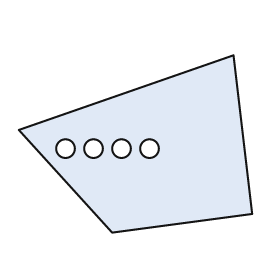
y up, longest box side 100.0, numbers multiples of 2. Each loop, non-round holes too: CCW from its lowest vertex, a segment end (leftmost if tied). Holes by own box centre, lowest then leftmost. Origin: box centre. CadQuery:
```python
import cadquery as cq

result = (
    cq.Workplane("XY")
    .moveTo(-10.0, -38.0)
    .lineTo(50.0, -30.0)
    .lineTo(42.0, 38.0)
    .lineTo(-50.0, 6.0)
    .close()
    .moveTo(-30.0, -2.0)
    .circle(4.0)
    .moveTo(-18.0, -2.0)
    .circle(4.0)
    .moveTo(-6.0, -2.0)
    .circle(4.0)
    .moveTo(6.0, -2.0)
    .circle(4.0)
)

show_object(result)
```